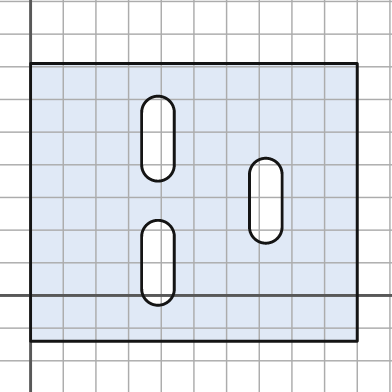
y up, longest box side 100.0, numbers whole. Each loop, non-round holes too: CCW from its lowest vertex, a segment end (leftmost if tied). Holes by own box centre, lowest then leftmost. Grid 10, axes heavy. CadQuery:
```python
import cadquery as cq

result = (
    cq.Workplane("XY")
    .moveTo(0.0, -14.0)
    .lineTo(100.0, -14.0)
    .lineTo(100.0, 71.0)
    .lineTo(0.0, 71.0)
    .close()
    .moveTo(34.0, 2.0)
    .threePointArc((39.0, -3.0), (44.0, 2.0))
    .lineTo(44.0, 18.0)
    .threePointArc((39.0, 23.0), (34.0, 18.0))
    .close()
    .moveTo(67.0, 21.0)
    .threePointArc((72.0, 16.0), (77.0, 21.0))
    .lineTo(77.0, 37.0)
    .threePointArc((72.0, 42.0), (67.0, 37.0))
    .close()
    .moveTo(34.0, 40.0)
    .threePointArc((39.0, 35.0), (44.0, 40.0))
    .lineTo(44.0, 56.0)
    .threePointArc((39.0, 61.0), (34.0, 56.0))
    .close()
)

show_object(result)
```